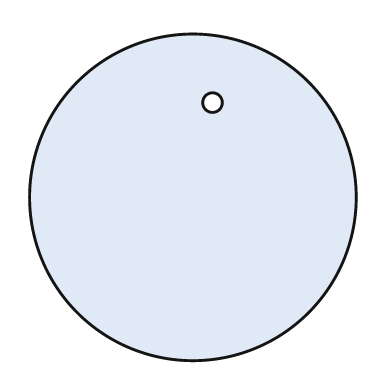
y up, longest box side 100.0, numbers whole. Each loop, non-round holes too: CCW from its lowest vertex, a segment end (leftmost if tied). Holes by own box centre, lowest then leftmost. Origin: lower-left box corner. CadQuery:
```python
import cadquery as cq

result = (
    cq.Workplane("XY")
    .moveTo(50.0, 50.0)
    .circle(50.0)
    .moveTo(56.0, 79.0)
    .circle(3.0)
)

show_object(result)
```